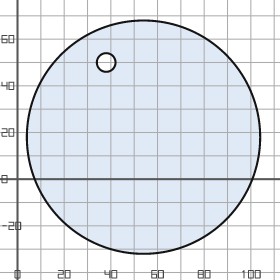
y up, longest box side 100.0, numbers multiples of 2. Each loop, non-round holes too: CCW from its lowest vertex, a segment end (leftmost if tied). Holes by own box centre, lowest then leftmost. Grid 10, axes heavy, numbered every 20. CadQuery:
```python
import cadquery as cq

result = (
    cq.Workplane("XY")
    .moveTo(54.0, 18.0)
    .circle(50.0)
    .moveTo(38.0, 50.0)
    .circle(4.0)
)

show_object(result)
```